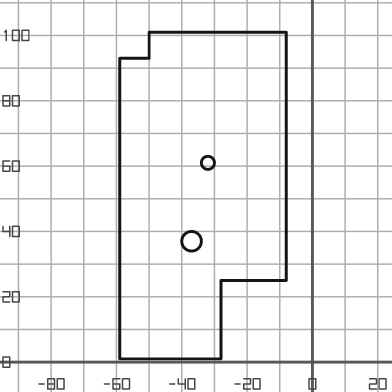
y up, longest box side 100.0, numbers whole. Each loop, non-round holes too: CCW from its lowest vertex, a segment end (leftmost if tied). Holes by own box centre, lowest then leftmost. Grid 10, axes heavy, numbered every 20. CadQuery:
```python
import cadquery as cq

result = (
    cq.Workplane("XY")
    .moveTo(-59.0, 1.0)
    .lineTo(-28.0, 1.0)
    .lineTo(-28.0, 25.0)
    .lineTo(-8.0, 25.0)
    .lineTo(-8.0, 101.0)
    .lineTo(-50.0, 101.0)
    .lineTo(-50.0, 93.0)
    .lineTo(-59.0, 93.0)
    .close()
    .moveTo(-37.0, 37.0)
    .circle(3.0)
    .moveTo(-32.0, 61.0)
    .circle(2.0)
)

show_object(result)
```